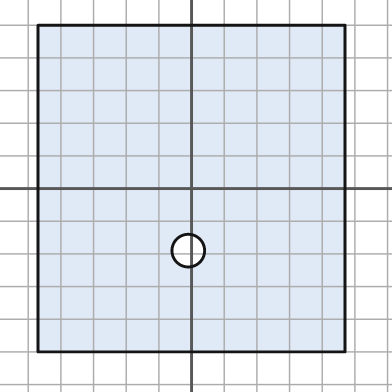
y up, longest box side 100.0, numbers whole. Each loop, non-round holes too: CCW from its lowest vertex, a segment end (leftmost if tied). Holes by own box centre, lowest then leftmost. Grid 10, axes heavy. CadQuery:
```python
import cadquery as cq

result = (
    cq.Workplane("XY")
    .moveTo(-47.0, -50.0)
    .lineTo(47.0, -50.0)
    .lineTo(47.0, 50.0)
    .lineTo(-47.0, 50.0)
    .close()
    .moveTo(-1.0, -19.0)
    .circle(5.0)
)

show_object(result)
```